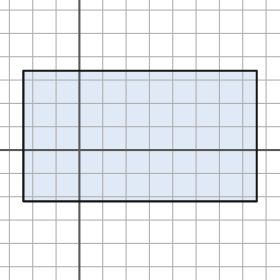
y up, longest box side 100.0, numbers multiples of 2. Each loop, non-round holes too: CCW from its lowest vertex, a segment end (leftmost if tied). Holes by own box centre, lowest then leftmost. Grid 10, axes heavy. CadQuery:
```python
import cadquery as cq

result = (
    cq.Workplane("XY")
    .moveTo(-24.0, -22.0)
    .lineTo(76.0, -22.0)
    .lineTo(76.0, 34.0)
    .lineTo(-24.0, 34.0)
    .close()
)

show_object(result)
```